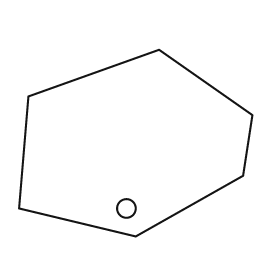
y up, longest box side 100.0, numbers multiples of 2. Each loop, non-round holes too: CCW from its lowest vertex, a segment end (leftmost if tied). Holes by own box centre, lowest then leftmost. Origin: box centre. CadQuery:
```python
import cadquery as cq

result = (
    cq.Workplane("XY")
    .moveTo(0.0, -40.0)
    .lineTo(46.0, -14.0)
    .lineTo(50.0, 12.0)
    .lineTo(10.0, 40.0)
    .lineTo(-46.0, 20.0)
    .lineTo(-50.0, -28.0)
    .close()
    .moveTo(-4.0, -28.0)
    .circle(4.0)
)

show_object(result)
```